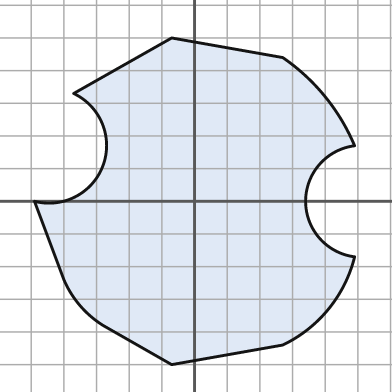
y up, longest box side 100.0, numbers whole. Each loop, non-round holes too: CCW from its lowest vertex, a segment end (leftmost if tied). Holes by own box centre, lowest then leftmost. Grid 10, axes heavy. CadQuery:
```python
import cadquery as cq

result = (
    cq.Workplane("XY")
    .moveTo(-7.0, -50.0)
    .lineTo(27.0, -44.0)
    .threePointArc((41.0, -33.0), (49.0, -17.0))
    .threePointArc((34.0, 0.0), (49.0, 17.0))
    .threePointArc((40.0, 32.0), (27.0, 44.0))
    .lineTo(-7.0, 50.0)
    .lineTo(-37.0, 33.0)
    .threePointArc((-28.0, 11.0), (-49.0, 0.0))
    .lineTo(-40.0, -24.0)
    .threePointArc((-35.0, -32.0), (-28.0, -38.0))
    .close()
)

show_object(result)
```